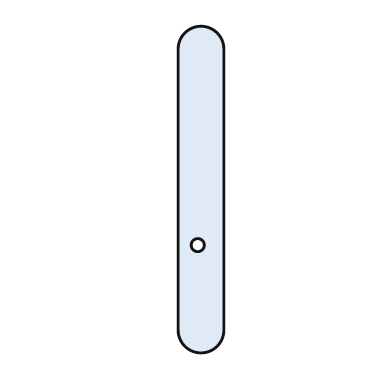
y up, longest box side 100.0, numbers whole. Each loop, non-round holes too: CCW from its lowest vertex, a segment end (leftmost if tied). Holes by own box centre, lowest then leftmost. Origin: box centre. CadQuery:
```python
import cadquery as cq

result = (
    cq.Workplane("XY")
    .moveTo(-7.0, -43.0)
    .threePointArc((0.0, -50.0), (7.0, -43.0))
    .lineTo(7.0, 43.0)
    .threePointArc((0.0, 50.0), (-7.0, 43.0))
    .close()
    .moveTo(-1.0, -17.0)
    .circle(2.0)
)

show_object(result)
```